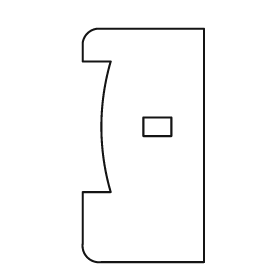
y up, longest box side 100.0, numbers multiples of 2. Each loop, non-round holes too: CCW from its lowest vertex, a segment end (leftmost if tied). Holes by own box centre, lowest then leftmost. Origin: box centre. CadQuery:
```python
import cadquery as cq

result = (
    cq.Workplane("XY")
    .moveTo(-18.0, -50.0)
    .lineTo(26.0, -50.0)
    .lineTo(26.0, 50.0)
    .lineTo(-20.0, 50.0)
    .threePointArc((-24.0, 48.0), (-26.0, 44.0))
    .lineTo(-26.0, 36.0)
    .lineTo(-14.0, 36.0)
    .threePointArc((-18.0, 8.0), (-14.0, -20.0))
    .lineTo(-26.0, -20.0)
    .lineTo(-26.0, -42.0)
    .threePointArc((-24.0, -48.0), (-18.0, -50.0))
    .close()
    .moveTo(0.0, 4.0)
    .lineTo(12.0, 4.0)
    .lineTo(12.0, 12.0)
    .lineTo(0.0, 12.0)
    .close()
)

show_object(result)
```